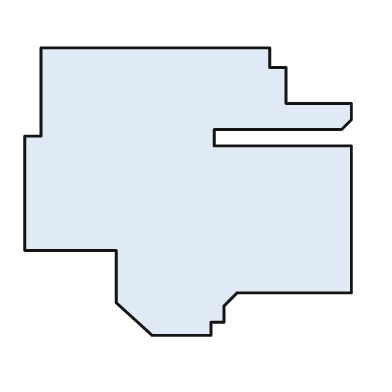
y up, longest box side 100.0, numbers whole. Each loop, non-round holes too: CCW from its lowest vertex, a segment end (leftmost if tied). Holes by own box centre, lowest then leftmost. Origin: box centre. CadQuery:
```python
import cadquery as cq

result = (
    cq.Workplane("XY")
    .moveTo(-11.0, -44.0)
    .lineTo(7.0, -44.0)
    .lineTo(7.0, -40.0)
    .lineTo(11.0, -40.0)
    .lineTo(11.0, -35.0)
    .lineTo(15.0, -31.0)
    .lineTo(50.0, -31.0)
    .lineTo(50.0, 14.0)
    .lineTo(8.0, 14.0)
    .lineTo(8.0, 19.0)
    .lineTo(47.0, 19.0)
    .lineTo(50.0, 22.0)
    .lineTo(50.0, 27.0)
    .lineTo(30.0, 27.0)
    .lineTo(30.0, 38.0)
    .lineTo(25.0, 38.0)
    .lineTo(25.0, 44.0)
    .lineTo(-45.0, 44.0)
    .lineTo(-45.0, 17.0)
    .lineTo(-50.0, 17.0)
    .lineTo(-50.0, -18.0)
    .lineTo(-22.0, -18.0)
    .lineTo(-22.0, -34.0)
    .close()
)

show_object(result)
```